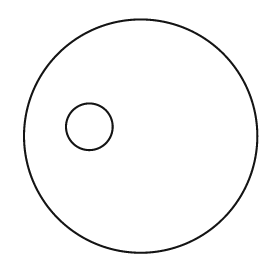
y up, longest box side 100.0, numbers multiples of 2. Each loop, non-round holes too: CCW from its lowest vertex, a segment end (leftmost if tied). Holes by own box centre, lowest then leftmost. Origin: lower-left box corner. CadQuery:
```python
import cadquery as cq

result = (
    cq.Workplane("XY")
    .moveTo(50.0, 50.0)
    .circle(50.0)
    .moveTo(28.0, 54.0)
    .circle(10.0)
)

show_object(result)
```